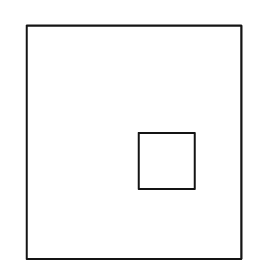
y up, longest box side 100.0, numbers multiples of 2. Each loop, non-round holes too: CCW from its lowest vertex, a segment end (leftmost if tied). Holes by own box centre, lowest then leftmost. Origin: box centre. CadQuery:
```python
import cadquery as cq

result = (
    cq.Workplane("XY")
    .moveTo(-46.0, -50.0)
    .lineTo(46.0, -50.0)
    .lineTo(46.0, 50.0)
    .lineTo(-46.0, 50.0)
    .close()
    .moveTo(2.0, -20.0)
    .lineTo(26.0, -20.0)
    .lineTo(26.0, 4.0)
    .lineTo(2.0, 4.0)
    .close()
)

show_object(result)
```